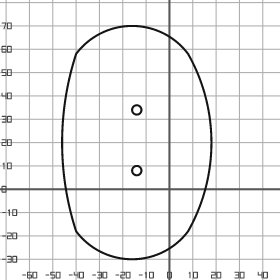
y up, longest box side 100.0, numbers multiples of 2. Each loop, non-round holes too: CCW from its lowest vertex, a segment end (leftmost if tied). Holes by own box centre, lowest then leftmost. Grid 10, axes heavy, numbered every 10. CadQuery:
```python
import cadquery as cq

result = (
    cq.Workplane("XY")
    .moveTo(-40.0, -18.0)
    .threePointArc((-16.0, -30.0), (8.0, -18.0))
    .threePointArc((18.0, 20.0), (8.0, 58.0))
    .threePointArc((-16.0, 70.0), (-40.0, 58.0))
    .threePointArc((-46.0, 20.0), (-40.0, -18.0))
    .close()
    .moveTo(-14.0, 8.0)
    .circle(2.0)
    .moveTo(-14.0, 34.0)
    .circle(2.0)
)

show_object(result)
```